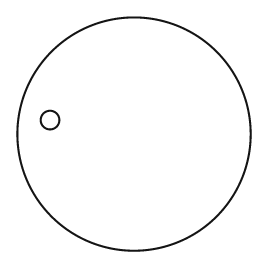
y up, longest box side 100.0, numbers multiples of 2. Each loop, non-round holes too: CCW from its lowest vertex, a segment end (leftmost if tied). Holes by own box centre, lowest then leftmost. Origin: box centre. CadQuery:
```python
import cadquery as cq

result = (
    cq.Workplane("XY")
    .moveTo(0.0, 0.0)
    .circle(50.0)
    .moveTo(-36.0, 6.0)
    .circle(4.0)
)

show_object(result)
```